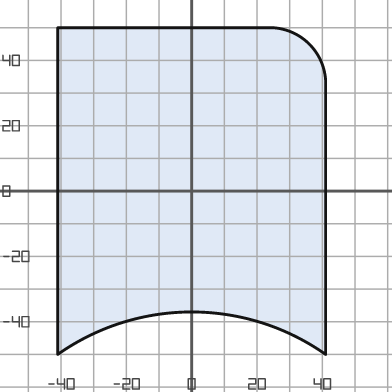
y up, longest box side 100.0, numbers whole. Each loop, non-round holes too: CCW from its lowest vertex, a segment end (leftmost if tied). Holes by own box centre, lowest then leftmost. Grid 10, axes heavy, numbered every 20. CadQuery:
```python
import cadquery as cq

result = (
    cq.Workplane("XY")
    .moveTo(-41.0, -50.0)
    .threePointArc((0.0, -37.0), (41.0, -50.0))
    .lineTo(41.0, 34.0)
    .threePointArc((36.0, 45.0), (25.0, 50.0))
    .lineTo(-41.0, 50.0)
    .close()
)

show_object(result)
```